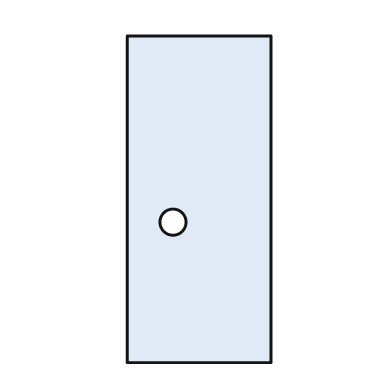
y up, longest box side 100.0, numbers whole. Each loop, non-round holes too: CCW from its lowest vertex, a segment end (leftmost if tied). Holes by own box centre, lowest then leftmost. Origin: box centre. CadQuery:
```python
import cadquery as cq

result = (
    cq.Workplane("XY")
    .moveTo(-22.0, -50.0)
    .lineTo(22.0, -50.0)
    .lineTo(22.0, 50.0)
    .lineTo(-22.0, 50.0)
    .close()
    .moveTo(-8.0, -7.0)
    .circle(4.0)
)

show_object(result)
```